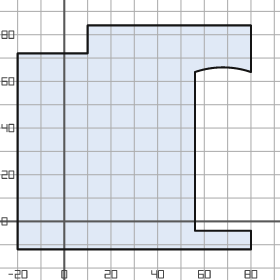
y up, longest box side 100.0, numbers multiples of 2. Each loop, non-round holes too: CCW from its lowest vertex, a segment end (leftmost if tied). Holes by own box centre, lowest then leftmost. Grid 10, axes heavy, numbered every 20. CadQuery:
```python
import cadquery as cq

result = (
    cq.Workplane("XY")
    .moveTo(-20.0, -12.0)
    .lineTo(80.0, -12.0)
    .lineTo(80.0, -4.0)
    .lineTo(56.0, -4.0)
    .lineTo(56.0, 64.0)
    .threePointArc((68.0, 66.0), (80.0, 64.0))
    .lineTo(80.0, 84.0)
    .lineTo(10.0, 84.0)
    .lineTo(10.0, 72.0)
    .lineTo(-20.0, 72.0)
    .close()
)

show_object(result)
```